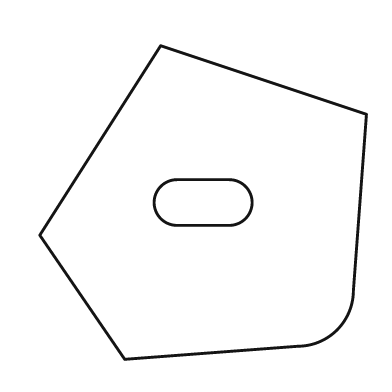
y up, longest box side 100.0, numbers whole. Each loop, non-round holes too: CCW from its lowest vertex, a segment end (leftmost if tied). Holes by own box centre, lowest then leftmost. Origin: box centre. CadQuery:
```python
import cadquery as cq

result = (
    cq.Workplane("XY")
    .moveTo(-24.0, -48.0)
    .lineTo(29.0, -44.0)
    .threePointArc((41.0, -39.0), (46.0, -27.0))
    .lineTo(50.0, 27.0)
    .lineTo(-13.0, 48.0)
    .lineTo(-50.0, -10.0)
    .close()
    .moveTo(-8.0, -7.0)
    .lineTo(8.0, -7.0)
    .threePointArc((15.0, 0.0), (8.0, 7.0))
    .lineTo(-8.0, 7.0)
    .threePointArc((-15.0, 0.0), (-8.0, -7.0))
    .close()
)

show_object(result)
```